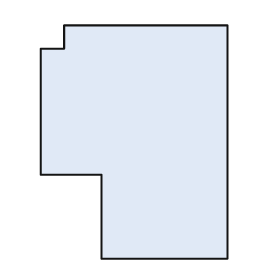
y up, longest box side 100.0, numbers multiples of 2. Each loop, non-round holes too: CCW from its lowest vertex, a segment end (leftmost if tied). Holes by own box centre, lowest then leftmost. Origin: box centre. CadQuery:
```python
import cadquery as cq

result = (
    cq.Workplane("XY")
    .moveTo(-14.0, -50.0)
    .lineTo(40.0, -50.0)
    .lineTo(40.0, 50.0)
    .lineTo(-30.0, 50.0)
    .lineTo(-30.0, 40.0)
    .lineTo(-40.0, 40.0)
    .lineTo(-40.0, -14.0)
    .lineTo(-14.0, -14.0)
    .close()
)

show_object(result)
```